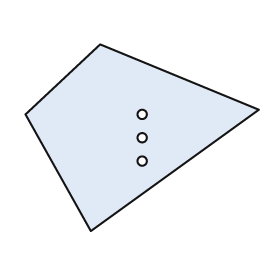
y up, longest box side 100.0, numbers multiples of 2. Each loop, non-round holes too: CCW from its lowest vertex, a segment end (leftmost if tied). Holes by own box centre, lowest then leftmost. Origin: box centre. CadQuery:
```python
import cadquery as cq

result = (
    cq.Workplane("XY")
    .moveTo(-22.0, -40.0)
    .lineTo(50.0, 12.0)
    .lineTo(-18.0, 40.0)
    .lineTo(-50.0, 10.0)
    .close()
    .moveTo(0.0, -10.0)
    .circle(2.0)
    .moveTo(0.0, 0.0)
    .circle(2.0)
    .moveTo(0.0, 10.0)
    .circle(2.0)
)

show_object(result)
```